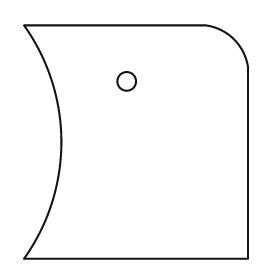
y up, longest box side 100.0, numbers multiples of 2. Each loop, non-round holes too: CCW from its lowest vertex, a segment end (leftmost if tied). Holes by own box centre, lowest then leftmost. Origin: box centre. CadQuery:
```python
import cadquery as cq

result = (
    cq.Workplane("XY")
    .moveTo(-48.0, -50.0)
    .lineTo(48.0, -50.0)
    .lineTo(48.0, 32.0)
    .threePointArc((42.0, 44.0), (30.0, 50.0))
    .lineTo(-48.0, 50.0)
    .threePointArc((-32.0, 0.0), (-48.0, -50.0))
    .close()
    .moveTo(-4.0, 26.0)
    .circle(4.0)
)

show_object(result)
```